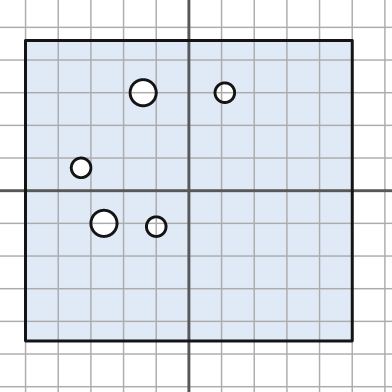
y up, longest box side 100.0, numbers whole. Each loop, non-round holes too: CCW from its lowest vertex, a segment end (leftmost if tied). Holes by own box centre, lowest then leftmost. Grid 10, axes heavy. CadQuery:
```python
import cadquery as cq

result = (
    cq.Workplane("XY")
    .moveTo(-50.0, -46.0)
    .lineTo(50.0, -46.0)
    .lineTo(50.0, 46.0)
    .lineTo(-50.0, 46.0)
    .close()
    .moveTo(-10.0, -11.0)
    .circle(3.0)
    .moveTo(-26.0, -10.0)
    .circle(4.0)
    .moveTo(-33.0, 7.0)
    .circle(3.0)
    .moveTo(-14.0, 30.0)
    .circle(4.0)
    .moveTo(11.0, 30.0)
    .circle(3.0)
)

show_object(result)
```